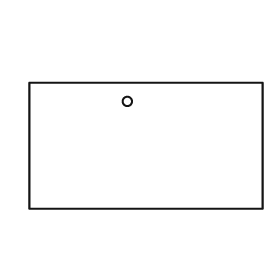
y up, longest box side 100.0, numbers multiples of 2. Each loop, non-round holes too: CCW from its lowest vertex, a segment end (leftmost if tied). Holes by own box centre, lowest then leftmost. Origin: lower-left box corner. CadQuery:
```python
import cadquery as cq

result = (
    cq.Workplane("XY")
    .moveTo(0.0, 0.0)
    .lineTo(100.0, 0.0)
    .lineTo(100.0, 54.0)
    .lineTo(0.0, 54.0)
    .close()
    .moveTo(42.0, 46.0)
    .circle(2.0)
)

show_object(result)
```